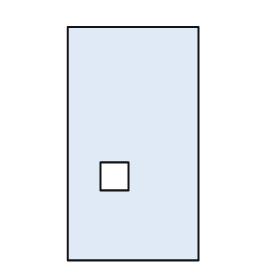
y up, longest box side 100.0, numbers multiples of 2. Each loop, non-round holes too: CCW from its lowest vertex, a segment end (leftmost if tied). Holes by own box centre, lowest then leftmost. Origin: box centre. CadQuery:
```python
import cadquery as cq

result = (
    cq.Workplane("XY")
    .moveTo(-28.0, -50.0)
    .lineTo(28.0, -50.0)
    .lineTo(28.0, 50.0)
    .lineTo(-28.0, 50.0)
    .close()
    .moveTo(-14.0, -20.0)
    .lineTo(-2.0, -20.0)
    .lineTo(-2.0, -8.0)
    .lineTo(-14.0, -8.0)
    .close()
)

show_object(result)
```